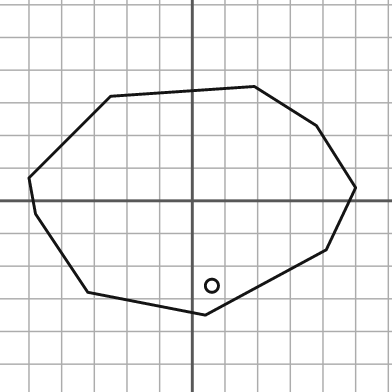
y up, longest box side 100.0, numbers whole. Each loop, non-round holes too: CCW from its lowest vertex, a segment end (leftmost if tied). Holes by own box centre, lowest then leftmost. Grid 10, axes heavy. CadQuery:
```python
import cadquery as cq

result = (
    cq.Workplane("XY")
    .moveTo(4.0, -35.0)
    .lineTo(41.0, -15.0)
    .lineTo(50.0, 4.0)
    .lineTo(38.0, 23.0)
    .lineTo(19.0, 35.0)
    .lineTo(-25.0, 32.0)
    .lineTo(-50.0, 7.0)
    .lineTo(-48.0, -4.0)
    .lineTo(-32.0, -28.0)
    .close()
    .moveTo(6.0, -26.0)
    .circle(2.0)
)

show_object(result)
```